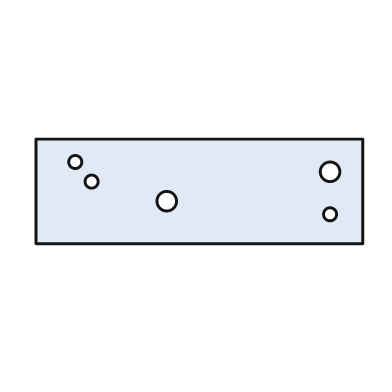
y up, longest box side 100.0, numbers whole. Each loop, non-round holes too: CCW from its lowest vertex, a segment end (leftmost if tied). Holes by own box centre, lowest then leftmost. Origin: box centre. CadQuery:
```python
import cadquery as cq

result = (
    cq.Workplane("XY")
    .moveTo(-50.0, -16.0)
    .lineTo(50.0, -16.0)
    .lineTo(50.0, 16.0)
    .lineTo(-50.0, 16.0)
    .close()
    .moveTo(40.0, -7.0)
    .circle(2.0)
    .moveTo(-10.0, -3.0)
    .circle(3.0)
    .moveTo(-33.0, 3.0)
    .circle(2.0)
    .moveTo(40.0, 6.0)
    .circle(3.0)
    .moveTo(-38.0, 9.0)
    .circle(2.0)
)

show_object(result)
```